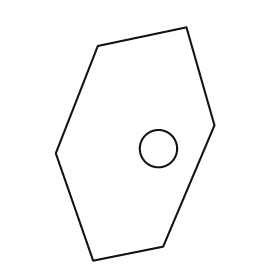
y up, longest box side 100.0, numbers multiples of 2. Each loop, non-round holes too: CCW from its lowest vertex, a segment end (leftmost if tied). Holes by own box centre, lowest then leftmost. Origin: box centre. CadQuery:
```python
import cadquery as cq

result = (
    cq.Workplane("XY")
    .moveTo(-18.0, -50.0)
    .lineTo(12.0, -44.0)
    .lineTo(34.0, 8.0)
    .lineTo(22.0, 50.0)
    .lineTo(-16.0, 42.0)
    .lineTo(-34.0, -4.0)
    .close()
    .moveTo(10.0, -2.0)
    .circle(8.0)
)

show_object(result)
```